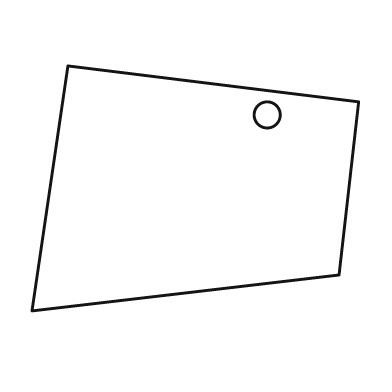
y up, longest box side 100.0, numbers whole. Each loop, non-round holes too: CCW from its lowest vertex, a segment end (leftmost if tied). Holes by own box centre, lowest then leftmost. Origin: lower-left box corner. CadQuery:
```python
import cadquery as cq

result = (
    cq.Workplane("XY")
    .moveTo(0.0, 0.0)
    .lineTo(94.0, 11.0)
    .lineTo(100.0, 64.0)
    .lineTo(11.0, 75.0)
    .close()
    .moveTo(72.0, 60.0)
    .circle(4.0)
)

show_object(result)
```